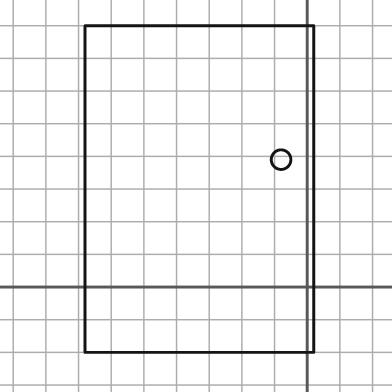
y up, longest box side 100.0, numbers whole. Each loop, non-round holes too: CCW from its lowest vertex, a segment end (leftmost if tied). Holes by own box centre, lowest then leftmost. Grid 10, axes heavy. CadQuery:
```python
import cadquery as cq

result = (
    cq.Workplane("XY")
    .moveTo(-68.0, -20.0)
    .lineTo(2.0, -20.0)
    .lineTo(2.0, 80.0)
    .lineTo(-68.0, 80.0)
    .close()
    .moveTo(-8.0, 39.0)
    .circle(3.0)
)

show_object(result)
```